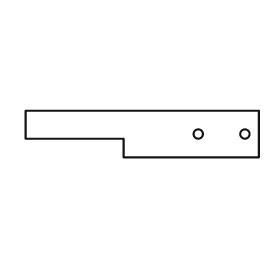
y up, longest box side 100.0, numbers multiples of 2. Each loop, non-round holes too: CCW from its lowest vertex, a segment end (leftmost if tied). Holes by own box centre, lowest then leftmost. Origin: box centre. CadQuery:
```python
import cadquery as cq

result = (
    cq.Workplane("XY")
    .moveTo(-8.0, -10.0)
    .lineTo(50.0, -10.0)
    .lineTo(50.0, 10.0)
    .lineTo(-50.0, 10.0)
    .lineTo(-50.0, -2.0)
    .lineTo(-8.0, -2.0)
    .close()
    .moveTo(24.0, 0.0)
    .circle(2.0)
    .moveTo(44.0, 0.0)
    .circle(2.0)
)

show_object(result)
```